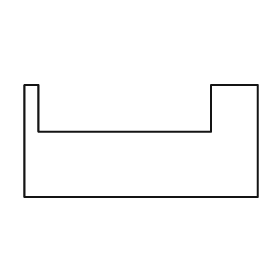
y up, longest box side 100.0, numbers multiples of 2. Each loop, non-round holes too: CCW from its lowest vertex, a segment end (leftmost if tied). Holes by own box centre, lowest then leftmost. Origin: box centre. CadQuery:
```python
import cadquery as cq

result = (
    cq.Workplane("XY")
    .moveTo(-50.0, -24.0)
    .lineTo(50.0, -24.0)
    .lineTo(50.0, 24.0)
    .lineTo(30.0, 24.0)
    .lineTo(30.0, 4.0)
    .lineTo(-44.0, 4.0)
    .lineTo(-44.0, 24.0)
    .lineTo(-50.0, 24.0)
    .close()
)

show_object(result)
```